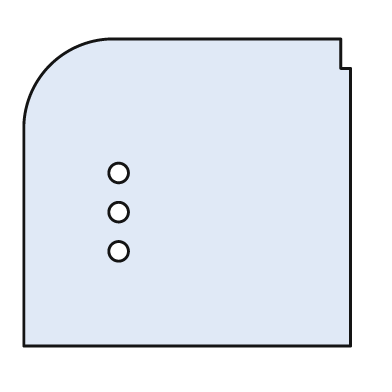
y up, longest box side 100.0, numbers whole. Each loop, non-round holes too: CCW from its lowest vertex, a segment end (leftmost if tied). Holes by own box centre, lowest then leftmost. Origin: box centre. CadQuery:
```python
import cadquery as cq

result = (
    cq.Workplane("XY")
    .moveTo(-50.0, -47.0)
    .lineTo(50.0, -47.0)
    .lineTo(50.0, 38.0)
    .lineTo(47.0, 38.0)
    .lineTo(47.0, 47.0)
    .lineTo(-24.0, 47.0)
    .threePointArc((-42.0, 39.0), (-50.0, 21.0))
    .close()
    .moveTo(-21.0, -18.0)
    .circle(3.0)
    .moveTo(-21.0, -6.0)
    .circle(3.0)
    .moveTo(-21.0, 6.0)
    .circle(3.0)
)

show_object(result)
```